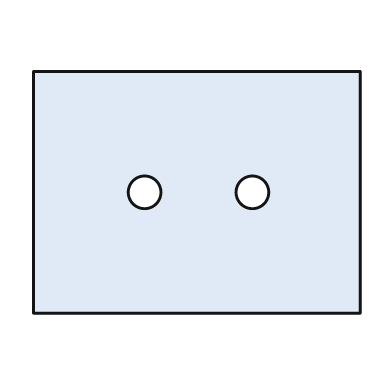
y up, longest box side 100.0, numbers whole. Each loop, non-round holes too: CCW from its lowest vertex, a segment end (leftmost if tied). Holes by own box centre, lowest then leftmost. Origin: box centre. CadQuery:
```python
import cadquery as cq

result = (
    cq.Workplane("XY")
    .moveTo(-50.0, -37.0)
    .lineTo(50.0, -37.0)
    .lineTo(50.0, 37.0)
    .lineTo(-50.0, 37.0)
    .close()
    .moveTo(-16.0, 0.0)
    .circle(5.0)
    .moveTo(17.0, 0.0)
    .circle(5.0)
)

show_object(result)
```